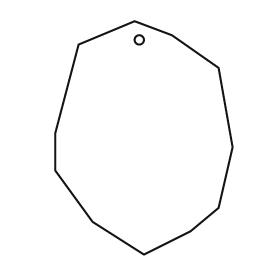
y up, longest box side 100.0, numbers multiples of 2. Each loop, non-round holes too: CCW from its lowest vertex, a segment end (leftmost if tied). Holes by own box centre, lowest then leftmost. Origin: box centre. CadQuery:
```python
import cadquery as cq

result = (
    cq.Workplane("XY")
    .moveTo(0.0, -50.0)
    .lineTo(20.0, -40.0)
    .lineTo(32.0, -30.0)
    .lineTo(38.0, -4.0)
    .lineTo(32.0, 30.0)
    .lineTo(12.0, 44.0)
    .lineTo(-4.0, 50.0)
    .lineTo(-28.0, 40.0)
    .lineTo(-38.0, 2.0)
    .lineTo(-38.0, -14.0)
    .lineTo(-22.0, -36.0)
    .close()
    .moveTo(-2.0, 42.0)
    .circle(2.0)
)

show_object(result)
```